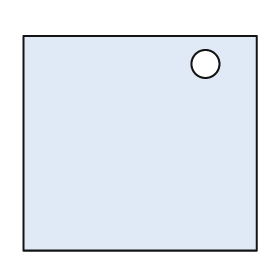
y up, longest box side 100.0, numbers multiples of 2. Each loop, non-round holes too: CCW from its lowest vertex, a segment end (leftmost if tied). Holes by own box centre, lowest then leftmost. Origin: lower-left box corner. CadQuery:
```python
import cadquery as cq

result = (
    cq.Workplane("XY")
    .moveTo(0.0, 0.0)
    .lineTo(100.0, 0.0)
    .lineTo(100.0, 92.0)
    .lineTo(0.0, 92.0)
    .close()
    .moveTo(78.0, 80.0)
    .circle(6.0)
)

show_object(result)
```